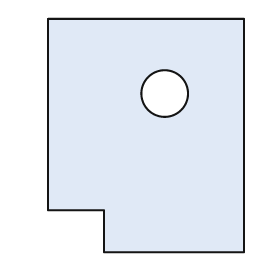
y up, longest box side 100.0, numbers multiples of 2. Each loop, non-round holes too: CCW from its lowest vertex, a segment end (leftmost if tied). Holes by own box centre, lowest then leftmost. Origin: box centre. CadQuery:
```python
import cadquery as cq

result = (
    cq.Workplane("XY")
    .moveTo(-18.0, -50.0)
    .lineTo(42.0, -50.0)
    .lineTo(42.0, 50.0)
    .lineTo(-42.0, 50.0)
    .lineTo(-42.0, -32.0)
    .lineTo(-18.0, -32.0)
    .close()
    .moveTo(8.0, 18.0)
    .circle(10.0)
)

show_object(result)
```